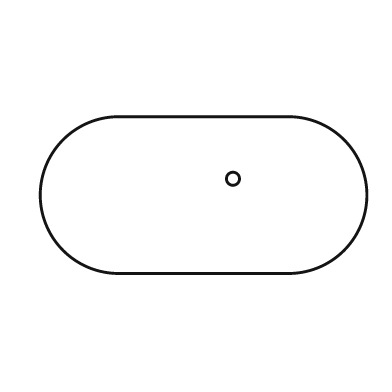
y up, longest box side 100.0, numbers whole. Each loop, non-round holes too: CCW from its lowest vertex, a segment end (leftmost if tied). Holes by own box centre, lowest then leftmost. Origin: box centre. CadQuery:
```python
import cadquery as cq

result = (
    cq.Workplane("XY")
    .moveTo(-26.0, -24.0)
    .lineTo(26.0, -24.0)
    .threePointArc((50.0, 0.0), (26.0, 24.0))
    .lineTo(-26.0, 24.0)
    .threePointArc((-50.0, 0.0), (-26.0, -24.0))
    .close()
    .moveTo(9.0, 5.0)
    .circle(2.0)
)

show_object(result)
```